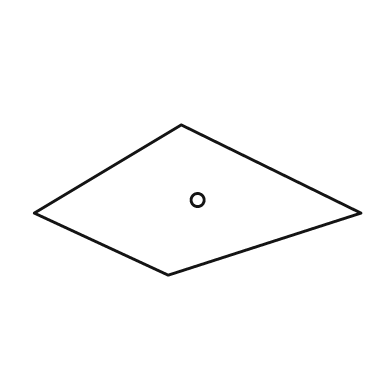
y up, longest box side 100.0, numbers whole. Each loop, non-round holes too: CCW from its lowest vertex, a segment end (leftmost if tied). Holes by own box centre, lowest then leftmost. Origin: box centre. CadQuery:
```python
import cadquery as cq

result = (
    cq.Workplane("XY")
    .moveTo(-9.0, -23.0)
    .lineTo(50.0, -4.0)
    .lineTo(-5.0, 23.0)
    .lineTo(-50.0, -4.0)
    .close()
    .moveTo(0.0, 0.0)
    .circle(2.0)
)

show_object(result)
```